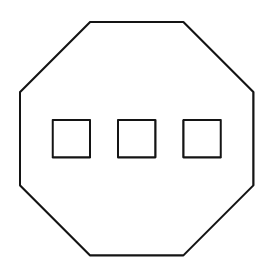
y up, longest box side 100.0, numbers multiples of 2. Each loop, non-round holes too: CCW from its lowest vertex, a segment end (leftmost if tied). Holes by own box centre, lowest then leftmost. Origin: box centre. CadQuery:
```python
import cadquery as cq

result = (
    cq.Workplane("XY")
    .moveTo(-20.0, -50.0)
    .lineTo(20.0, -50.0)
    .lineTo(50.0, -20.0)
    .lineTo(50.0, 20.0)
    .lineTo(20.0, 50.0)
    .lineTo(-20.0, 50.0)
    .lineTo(-50.0, 20.0)
    .lineTo(-50.0, -20.0)
    .close()
    .moveTo(-36.0, -8.0)
    .lineTo(-20.0, -8.0)
    .lineTo(-20.0, 8.0)
    .lineTo(-36.0, 8.0)
    .close()
    .moveTo(-8.0, -8.0)
    .lineTo(8.0, -8.0)
    .lineTo(8.0, 8.0)
    .lineTo(-8.0, 8.0)
    .close()
    .moveTo(20.0, -8.0)
    .lineTo(36.0, -8.0)
    .lineTo(36.0, 8.0)
    .lineTo(20.0, 8.0)
    .close()
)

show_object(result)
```